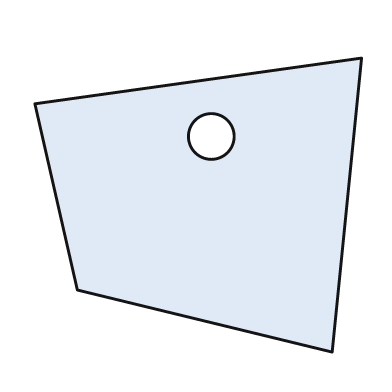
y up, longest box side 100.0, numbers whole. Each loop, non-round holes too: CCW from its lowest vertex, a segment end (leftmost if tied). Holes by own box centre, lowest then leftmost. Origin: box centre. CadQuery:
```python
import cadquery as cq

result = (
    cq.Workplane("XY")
    .moveTo(41.0, -45.0)
    .lineTo(50.0, 45.0)
    .lineTo(-50.0, 31.0)
    .lineTo(-37.0, -26.0)
    .close()
    .moveTo(4.0, 21.0)
    .circle(7.0)
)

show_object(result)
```